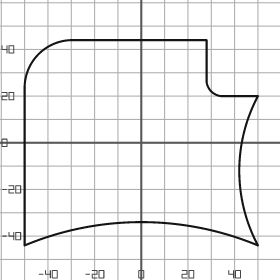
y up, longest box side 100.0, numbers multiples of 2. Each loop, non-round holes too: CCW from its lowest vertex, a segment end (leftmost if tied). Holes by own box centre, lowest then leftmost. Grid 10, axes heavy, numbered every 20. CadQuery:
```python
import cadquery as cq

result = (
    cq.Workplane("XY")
    .moveTo(-50.0, -44.0)
    .threePointArc((0.0, -34.0), (50.0, -44.0))
    .threePointArc((42.0, -12.0), (50.0, 20.0))
    .lineTo(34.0, 20.0)
    .threePointArc((30.0, 22.0), (28.0, 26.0))
    .lineTo(28.0, 44.0)
    .lineTo(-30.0, 44.0)
    .threePointArc((-44.0, 38.0), (-50.0, 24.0))
    .close()
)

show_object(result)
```